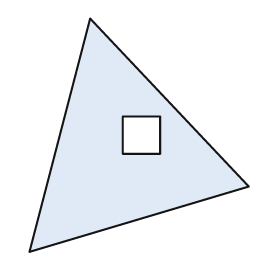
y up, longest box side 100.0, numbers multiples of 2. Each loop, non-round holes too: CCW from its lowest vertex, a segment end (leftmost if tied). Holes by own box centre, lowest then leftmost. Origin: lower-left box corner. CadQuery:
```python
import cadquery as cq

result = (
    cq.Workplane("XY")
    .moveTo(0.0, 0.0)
    .lineTo(94.0, 28.0)
    .lineTo(26.0, 100.0)
    .close()
    .moveTo(40.0, 42.0)
    .lineTo(56.0, 42.0)
    .lineTo(56.0, 58.0)
    .lineTo(40.0, 58.0)
    .close()
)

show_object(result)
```